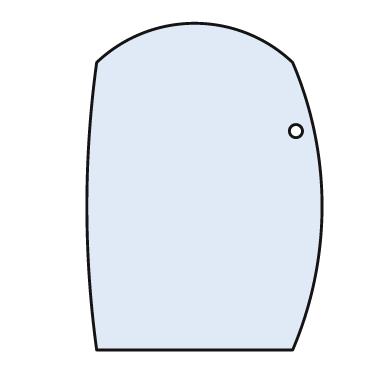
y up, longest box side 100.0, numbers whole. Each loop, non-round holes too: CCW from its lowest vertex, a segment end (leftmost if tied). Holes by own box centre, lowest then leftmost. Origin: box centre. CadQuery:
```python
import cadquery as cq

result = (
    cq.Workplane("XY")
    .moveTo(-33.0, -50.0)
    .lineTo(27.0, -50.0)
    .threePointArc((36.0, -6.0), (27.0, 38.0))
    .threePointArc((-3.0, 50.0), (-33.0, 38.0))
    .threePointArc((-36.0, -6.0), (-33.0, -50.0))
    .close()
    .moveTo(28.0, 17.0)
    .circle(2.0)
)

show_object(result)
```